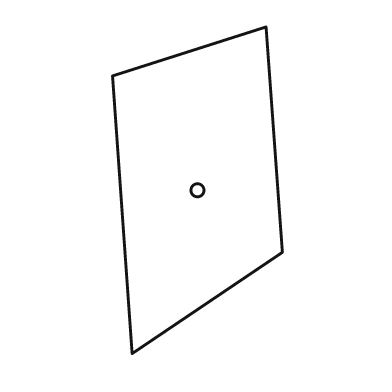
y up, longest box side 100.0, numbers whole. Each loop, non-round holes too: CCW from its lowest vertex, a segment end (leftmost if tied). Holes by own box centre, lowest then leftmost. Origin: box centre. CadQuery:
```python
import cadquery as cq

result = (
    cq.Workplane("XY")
    .moveTo(-20.0, -50.0)
    .lineTo(26.0, -19.0)
    .lineTo(21.0, 50.0)
    .lineTo(-26.0, 35.0)
    .close()
    .moveTo(0.0, 0.0)
    .circle(2.0)
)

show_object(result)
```